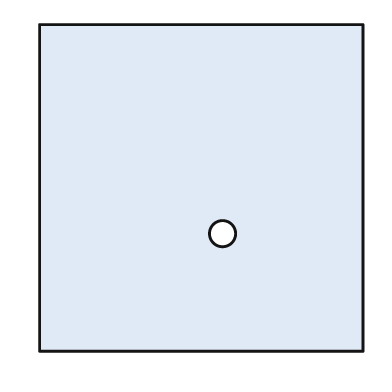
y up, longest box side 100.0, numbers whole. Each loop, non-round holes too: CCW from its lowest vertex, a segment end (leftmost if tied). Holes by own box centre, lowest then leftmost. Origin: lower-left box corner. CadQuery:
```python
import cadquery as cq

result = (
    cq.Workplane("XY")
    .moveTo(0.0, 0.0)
    .lineTo(99.0, 0.0)
    .lineTo(99.0, 100.0)
    .lineTo(0.0, 100.0)
    .close()
    .moveTo(56.0, 36.0)
    .circle(4.0)
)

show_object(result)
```